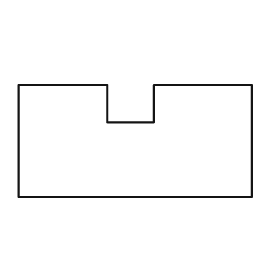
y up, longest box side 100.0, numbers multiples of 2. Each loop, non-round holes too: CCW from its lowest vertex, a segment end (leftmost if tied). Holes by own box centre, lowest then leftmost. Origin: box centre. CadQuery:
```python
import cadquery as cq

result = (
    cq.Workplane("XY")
    .moveTo(-50.0, -24.0)
    .lineTo(50.0, -24.0)
    .lineTo(50.0, 24.0)
    .lineTo(8.0, 24.0)
    .lineTo(8.0, 8.0)
    .lineTo(-12.0, 8.0)
    .lineTo(-12.0, 24.0)
    .lineTo(-50.0, 24.0)
    .close()
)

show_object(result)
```